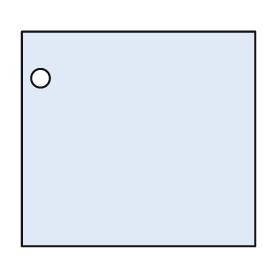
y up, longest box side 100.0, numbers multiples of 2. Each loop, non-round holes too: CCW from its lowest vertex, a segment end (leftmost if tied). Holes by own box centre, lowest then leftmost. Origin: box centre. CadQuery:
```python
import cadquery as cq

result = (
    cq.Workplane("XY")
    .moveTo(-50.0, -46.0)
    .lineTo(50.0, -46.0)
    .lineTo(50.0, 46.0)
    .lineTo(-50.0, 46.0)
    .close()
    .moveTo(-42.0, 26.0)
    .circle(4.0)
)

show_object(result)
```